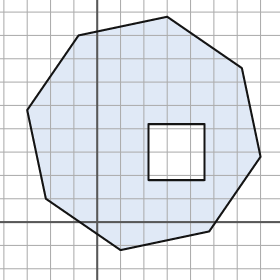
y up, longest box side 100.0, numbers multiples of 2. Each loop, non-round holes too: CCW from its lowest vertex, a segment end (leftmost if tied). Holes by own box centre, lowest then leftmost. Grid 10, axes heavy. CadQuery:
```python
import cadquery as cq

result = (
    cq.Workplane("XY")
    .moveTo(10.0, -12.0)
    .lineTo(48.0, -4.0)
    .lineTo(70.0, 28.0)
    .lineTo(62.0, 66.0)
    .lineTo(30.0, 88.0)
    .lineTo(-8.0, 80.0)
    .lineTo(-30.0, 48.0)
    .lineTo(-22.0, 10.0)
    .close()
    .moveTo(22.0, 18.0)
    .lineTo(46.0, 18.0)
    .lineTo(46.0, 42.0)
    .lineTo(22.0, 42.0)
    .close()
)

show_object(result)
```